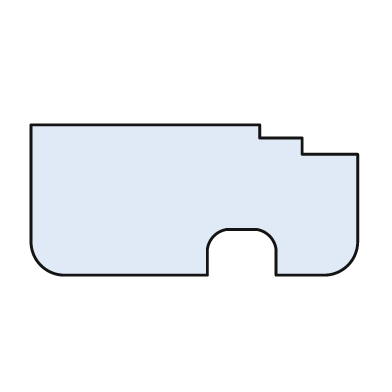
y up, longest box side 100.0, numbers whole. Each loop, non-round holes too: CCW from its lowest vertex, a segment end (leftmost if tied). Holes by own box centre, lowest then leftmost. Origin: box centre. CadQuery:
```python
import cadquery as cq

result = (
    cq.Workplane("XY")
    .moveTo(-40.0, -23.0)
    .lineTo(4.0, -23.0)
    .lineTo(4.0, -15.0)
    .threePointArc((6.0, -11.0), (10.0, -9.0))
    .lineTo(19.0, -9.0)
    .threePointArc((23.0, -11.0), (25.0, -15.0))
    .lineTo(25.0, -23.0)
    .lineTo(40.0, -23.0)
    .threePointArc((47.0, -20.0), (50.0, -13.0))
    .lineTo(50.0, 14.0)
    .lineTo(33.0, 14.0)
    .lineTo(33.0, 19.0)
    .lineTo(20.0, 19.0)
    .lineTo(20.0, 23.0)
    .lineTo(-50.0, 23.0)
    .lineTo(-50.0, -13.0)
    .threePointArc((-47.0, -20.0), (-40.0, -23.0))
    .close()
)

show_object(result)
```